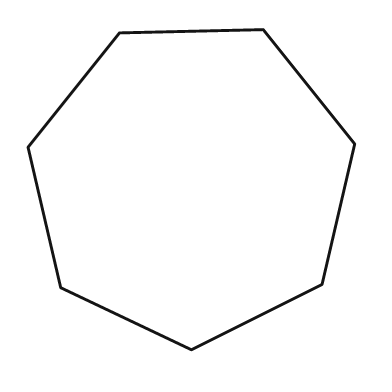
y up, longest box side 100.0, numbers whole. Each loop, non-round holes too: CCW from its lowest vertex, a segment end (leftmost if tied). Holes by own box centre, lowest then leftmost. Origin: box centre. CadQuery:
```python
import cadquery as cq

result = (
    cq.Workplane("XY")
    .moveTo(0.0, -49.0)
    .lineTo(40.0, -29.0)
    .lineTo(50.0, 14.0)
    .lineTo(22.0, 49.0)
    .lineTo(-22.0, 48.0)
    .lineTo(-50.0, 13.0)
    .lineTo(-40.0, -30.0)
    .close()
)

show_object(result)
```